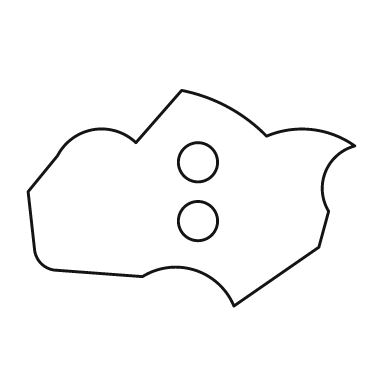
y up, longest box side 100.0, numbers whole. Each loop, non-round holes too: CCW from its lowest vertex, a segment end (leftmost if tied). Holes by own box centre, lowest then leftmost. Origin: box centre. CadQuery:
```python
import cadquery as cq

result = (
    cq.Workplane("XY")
    .moveTo(13.0, -33.0)
    .lineTo(39.0, -15.0)
    .lineTo(42.0, -4.0)
    .threePointArc((41.0, 8.0), (50.0, 16.0))
    .threePointArc((37.0, 21.0), (23.0, 19.0))
    .threePointArc((11.0, 28.0), (-3.0, 33.0))
    .lineTo(-17.0, 17.0)
    .threePointArc((-30.0, 21.0), (-41.0, 13.0))
    .lineTo(-50.0, 2.0)
    .lineTo(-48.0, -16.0)
    .threePointArc((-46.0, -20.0), (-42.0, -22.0))
    .lineTo(-15.0, -24.0)
    .threePointArc((1.0, -22.0), (13.0, -33.0))
    .close()
    .moveTo(2.0, -7.0)
    .circle(6.0)
    .moveTo(2.0, 11.0)
    .circle(6.0)
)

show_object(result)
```